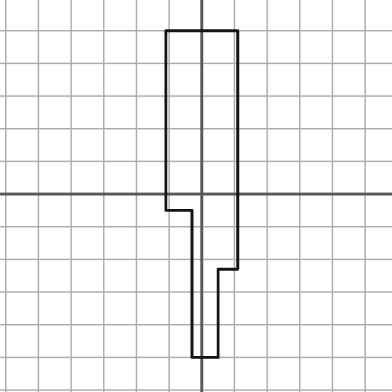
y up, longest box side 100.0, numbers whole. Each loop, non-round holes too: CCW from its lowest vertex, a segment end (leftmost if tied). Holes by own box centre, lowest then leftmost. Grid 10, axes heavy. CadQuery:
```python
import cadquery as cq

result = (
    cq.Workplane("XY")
    .moveTo(-3.0, -50.0)
    .lineTo(5.0, -50.0)
    .lineTo(5.0, -23.0)
    .lineTo(11.0, -23.0)
    .lineTo(11.0, 50.0)
    .lineTo(-11.0, 50.0)
    .lineTo(-11.0, -5.0)
    .lineTo(-3.0, -5.0)
    .close()
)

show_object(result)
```